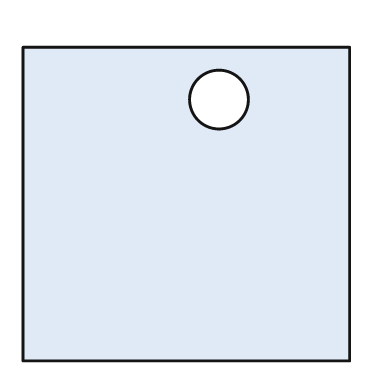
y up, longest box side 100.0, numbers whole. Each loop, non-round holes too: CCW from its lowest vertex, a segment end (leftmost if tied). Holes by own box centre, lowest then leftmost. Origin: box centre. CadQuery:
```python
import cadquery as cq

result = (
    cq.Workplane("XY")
    .moveTo(-50.0, -48.0)
    .lineTo(50.0, -48.0)
    .lineTo(50.0, 48.0)
    .lineTo(-50.0, 48.0)
    .close()
    .moveTo(10.0, 32.0)
    .circle(9.0)
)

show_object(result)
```